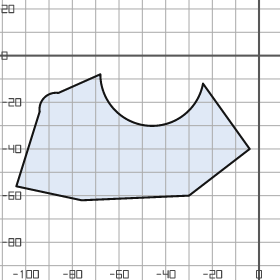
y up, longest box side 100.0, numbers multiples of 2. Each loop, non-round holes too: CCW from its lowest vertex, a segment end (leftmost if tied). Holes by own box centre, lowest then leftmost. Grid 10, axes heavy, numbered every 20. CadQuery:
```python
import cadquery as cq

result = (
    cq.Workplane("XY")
    .moveTo(-76.0, -62.0)
    .lineTo(-30.0, -60.0)
    .lineTo(-4.0, -40.0)
    .lineTo(-24.0, -12.0)
    .threePointArc((-48.0, -30.0), (-68.0, -8.0))
    .lineTo(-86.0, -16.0)
    .threePointArc((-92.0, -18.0), (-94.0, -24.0))
    .lineTo(-104.0, -56.0)
    .close()
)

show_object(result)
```